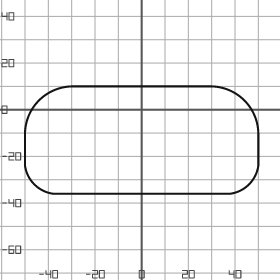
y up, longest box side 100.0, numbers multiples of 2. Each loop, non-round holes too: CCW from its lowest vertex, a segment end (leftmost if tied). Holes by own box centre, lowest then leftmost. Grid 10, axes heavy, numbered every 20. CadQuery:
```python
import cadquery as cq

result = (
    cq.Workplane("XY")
    .moveTo(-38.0, -36.0)
    .lineTo(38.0, -36.0)
    .threePointArc((46.0, -32.0), (50.0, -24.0))
    .lineTo(50.0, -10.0)
    .threePointArc((44.0, 4.0), (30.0, 10.0))
    .lineTo(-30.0, 10.0)
    .threePointArc((-44.0, 4.0), (-50.0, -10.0))
    .lineTo(-50.0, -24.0)
    .threePointArc((-46.0, -32.0), (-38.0, -36.0))
    .close()
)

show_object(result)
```